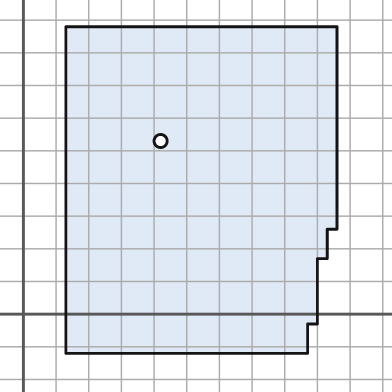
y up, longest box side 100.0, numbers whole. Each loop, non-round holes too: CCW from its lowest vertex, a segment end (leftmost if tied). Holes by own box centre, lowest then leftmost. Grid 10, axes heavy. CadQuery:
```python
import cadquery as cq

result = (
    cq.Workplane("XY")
    .moveTo(13.0, -12.0)
    .lineTo(87.0, -12.0)
    .lineTo(87.0, -3.0)
    .lineTo(90.0, -3.0)
    .lineTo(90.0, 17.0)
    .lineTo(93.0, 17.0)
    .lineTo(93.0, 26.0)
    .lineTo(96.0, 26.0)
    .lineTo(96.0, 88.0)
    .lineTo(13.0, 88.0)
    .close()
    .moveTo(42.0, 53.0)
    .circle(2.0)
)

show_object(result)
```